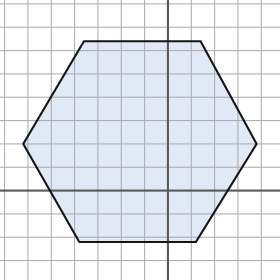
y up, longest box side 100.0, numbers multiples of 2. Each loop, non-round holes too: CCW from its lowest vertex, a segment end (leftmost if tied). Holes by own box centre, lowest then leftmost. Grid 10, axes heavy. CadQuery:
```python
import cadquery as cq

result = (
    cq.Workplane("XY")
    .moveTo(-38.0, -22.0)
    .lineTo(12.0, -22.0)
    .lineTo(38.0, 20.0)
    .lineTo(14.0, 64.0)
    .lineTo(-36.0, 64.0)
    .lineTo(-62.0, 20.0)
    .close()
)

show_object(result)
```